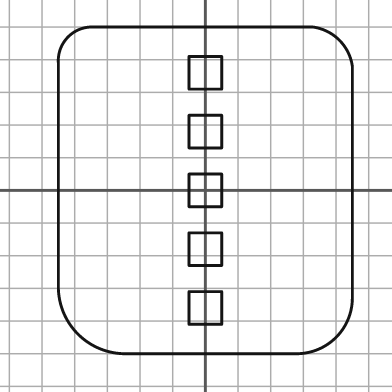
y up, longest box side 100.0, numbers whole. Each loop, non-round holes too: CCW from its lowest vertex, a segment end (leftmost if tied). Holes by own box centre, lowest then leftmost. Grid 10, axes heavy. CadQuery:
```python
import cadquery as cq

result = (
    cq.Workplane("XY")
    .moveTo(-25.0, -50.0)
    .lineTo(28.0, -50.0)
    .threePointArc((40.0, -45.0), (45.0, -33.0))
    .lineTo(45.0, 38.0)
    .threePointArc((41.0, 46.0), (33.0, 50.0))
    .lineTo(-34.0, 50.0)
    .threePointArc((-42.0, 47.0), (-45.0, 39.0))
    .lineTo(-45.0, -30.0)
    .threePointArc((-39.0, -44.0), (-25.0, -50.0))
    .close()
    .moveTo(-5.0, -41.0)
    .lineTo(5.0, -41.0)
    .lineTo(5.0, -31.0)
    .lineTo(-5.0, -31.0)
    .close()
    .moveTo(-5.0, -23.0)
    .lineTo(5.0, -23.0)
    .lineTo(5.0, -13.0)
    .lineTo(-5.0, -13.0)
    .close()
    .moveTo(-5.0, -5.0)
    .lineTo(5.0, -5.0)
    .lineTo(5.0, 5.0)
    .lineTo(-5.0, 5.0)
    .close()
    .moveTo(-5.0, 13.0)
    .lineTo(5.0, 13.0)
    .lineTo(5.0, 23.0)
    .lineTo(-5.0, 23.0)
    .close()
    .moveTo(-5.0, 31.0)
    .lineTo(5.0, 31.0)
    .lineTo(5.0, 41.0)
    .lineTo(-5.0, 41.0)
    .close()
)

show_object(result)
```